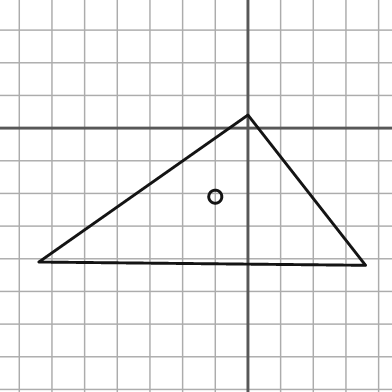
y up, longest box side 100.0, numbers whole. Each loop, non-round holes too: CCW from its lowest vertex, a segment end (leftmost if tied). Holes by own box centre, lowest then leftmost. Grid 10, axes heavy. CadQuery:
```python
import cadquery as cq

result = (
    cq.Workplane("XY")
    .moveTo(36.0, -42.0)
    .lineTo(0.0, 4.0)
    .lineTo(-64.0, -41.0)
    .close()
    .moveTo(-10.0, -21.0)
    .circle(2.0)
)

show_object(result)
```